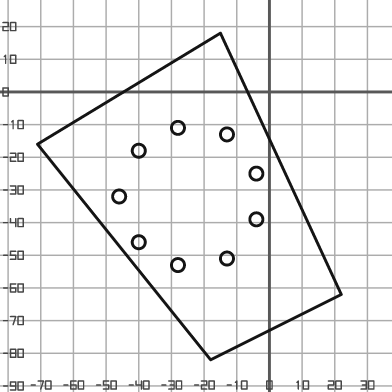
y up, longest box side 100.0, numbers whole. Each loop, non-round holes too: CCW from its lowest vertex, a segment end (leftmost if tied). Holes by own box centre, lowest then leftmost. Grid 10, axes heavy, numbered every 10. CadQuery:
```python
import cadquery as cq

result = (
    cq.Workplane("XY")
    .moveTo(-18.0, -82.0)
    .lineTo(22.0, -62.0)
    .lineTo(-15.0, 18.0)
    .lineTo(-71.0, -16.0)
    .close()
    .moveTo(-28.0, -53.0)
    .circle(2.0)
    .moveTo(-13.0, -51.0)
    .circle(2.0)
    .moveTo(-40.0, -46.0)
    .circle(2.0)
    .moveTo(-4.0, -39.0)
    .circle(2.0)
    .moveTo(-46.0, -32.0)
    .circle(2.0)
    .moveTo(-4.0, -25.0)
    .circle(2.0)
    .moveTo(-40.0, -18.0)
    .circle(2.0)
    .moveTo(-13.0, -13.0)
    .circle(2.0)
    .moveTo(-28.0, -11.0)
    .circle(2.0)
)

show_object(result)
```